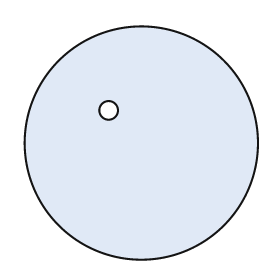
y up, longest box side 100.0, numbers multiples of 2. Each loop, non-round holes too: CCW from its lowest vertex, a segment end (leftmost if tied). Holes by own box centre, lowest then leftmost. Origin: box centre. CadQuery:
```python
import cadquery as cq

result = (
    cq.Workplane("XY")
    .moveTo(0.0, 0.0)
    .circle(50.0)
    .moveTo(-14.0, 14.0)
    .circle(4.0)
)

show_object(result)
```